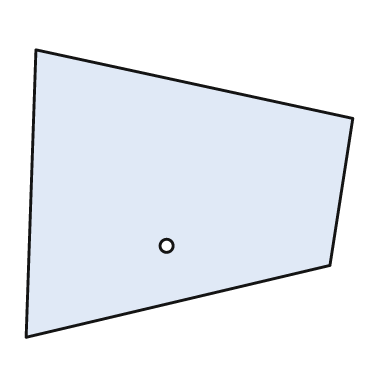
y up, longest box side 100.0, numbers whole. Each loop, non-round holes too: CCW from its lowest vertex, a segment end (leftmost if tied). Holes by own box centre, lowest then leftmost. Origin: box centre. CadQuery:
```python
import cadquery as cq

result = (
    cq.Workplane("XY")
    .moveTo(-50.0, -44.0)
    .lineTo(43.0, -22.0)
    .lineTo(50.0, 23.0)
    .lineTo(-47.0, 44.0)
    .close()
    .moveTo(-7.0, -16.0)
    .circle(2.0)
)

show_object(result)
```